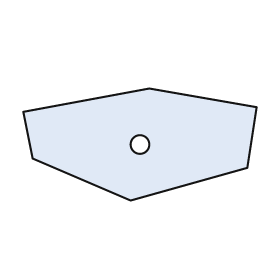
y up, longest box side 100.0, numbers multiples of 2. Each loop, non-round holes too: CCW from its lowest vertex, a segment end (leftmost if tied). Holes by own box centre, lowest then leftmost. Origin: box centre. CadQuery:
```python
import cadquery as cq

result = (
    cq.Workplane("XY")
    .moveTo(-4.0, -24.0)
    .lineTo(46.0, -10.0)
    .lineTo(50.0, 16.0)
    .lineTo(4.0, 24.0)
    .lineTo(-50.0, 14.0)
    .lineTo(-46.0, -6.0)
    .close()
    .moveTo(0.0, 0.0)
    .circle(4.0)
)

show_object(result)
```